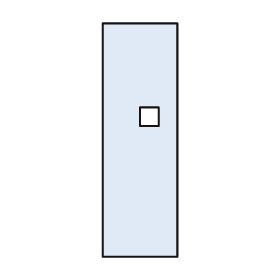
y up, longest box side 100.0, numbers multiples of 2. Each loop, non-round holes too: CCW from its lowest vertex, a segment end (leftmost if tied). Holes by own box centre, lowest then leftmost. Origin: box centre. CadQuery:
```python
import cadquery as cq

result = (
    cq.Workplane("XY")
    .moveTo(-16.0, -50.0)
    .lineTo(16.0, -50.0)
    .lineTo(16.0, 50.0)
    .lineTo(-16.0, 50.0)
    .close()
    .moveTo(0.0, 6.0)
    .lineTo(8.0, 6.0)
    .lineTo(8.0, 14.0)
    .lineTo(0.0, 14.0)
    .close()
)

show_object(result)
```